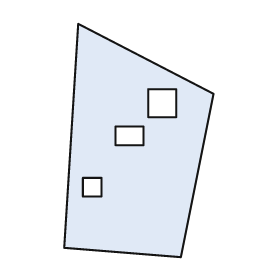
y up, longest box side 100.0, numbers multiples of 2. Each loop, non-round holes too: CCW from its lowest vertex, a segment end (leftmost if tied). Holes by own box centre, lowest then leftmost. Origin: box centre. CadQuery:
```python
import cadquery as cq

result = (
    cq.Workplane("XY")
    .moveTo(18.0, -50.0)
    .lineTo(32.0, 20.0)
    .lineTo(-26.0, 50.0)
    .lineTo(-32.0, -46.0)
    .close()
    .moveTo(-24.0, -24.0)
    .lineTo(-16.0, -24.0)
    .lineTo(-16.0, -16.0)
    .lineTo(-24.0, -16.0)
    .close()
    .moveTo(-10.0, -2.0)
    .lineTo(2.0, -2.0)
    .lineTo(2.0, 6.0)
    .lineTo(-10.0, 6.0)
    .close()
    .moveTo(4.0, 10.0)
    .lineTo(16.0, 10.0)
    .lineTo(16.0, 22.0)
    .lineTo(4.0, 22.0)
    .close()
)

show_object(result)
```